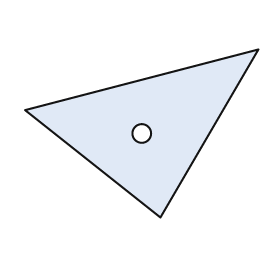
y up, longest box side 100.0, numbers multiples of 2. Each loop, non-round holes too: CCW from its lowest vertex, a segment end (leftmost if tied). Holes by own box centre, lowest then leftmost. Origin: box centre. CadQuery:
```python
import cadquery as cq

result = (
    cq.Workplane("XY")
    .moveTo(8.0, -36.0)
    .lineTo(50.0, 36.0)
    .lineTo(-50.0, 10.0)
    .close()
    .moveTo(0.0, 0.0)
    .circle(4.0)
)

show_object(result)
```